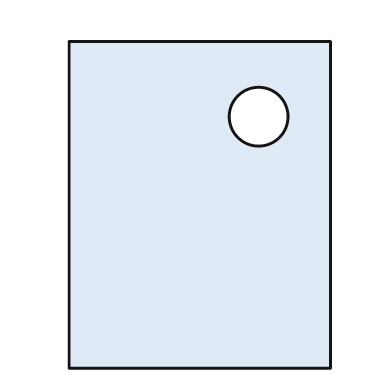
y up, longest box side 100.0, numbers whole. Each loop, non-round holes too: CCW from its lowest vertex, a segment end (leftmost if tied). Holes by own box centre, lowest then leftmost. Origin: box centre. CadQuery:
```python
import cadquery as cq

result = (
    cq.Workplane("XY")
    .moveTo(-40.0, -50.0)
    .lineTo(40.0, -50.0)
    .lineTo(40.0, 50.0)
    .lineTo(-40.0, 50.0)
    .close()
    .moveTo(18.0, 27.0)
    .circle(9.0)
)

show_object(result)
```